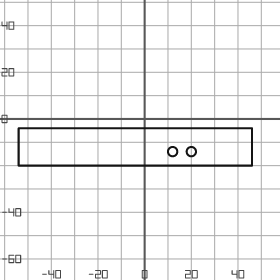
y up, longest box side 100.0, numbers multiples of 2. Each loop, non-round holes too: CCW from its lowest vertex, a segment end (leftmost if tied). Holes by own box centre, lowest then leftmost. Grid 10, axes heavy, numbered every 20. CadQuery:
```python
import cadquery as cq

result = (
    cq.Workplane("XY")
    .moveTo(-54.0, -20.0)
    .lineTo(46.0, -20.0)
    .lineTo(46.0, -4.0)
    .lineTo(-54.0, -4.0)
    .close()
    .moveTo(12.0, -14.0)
    .circle(2.0)
    .moveTo(20.0, -14.0)
    .circle(2.0)
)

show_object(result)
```